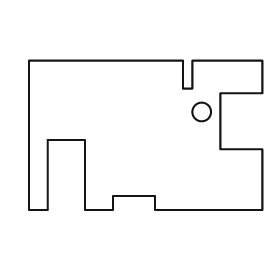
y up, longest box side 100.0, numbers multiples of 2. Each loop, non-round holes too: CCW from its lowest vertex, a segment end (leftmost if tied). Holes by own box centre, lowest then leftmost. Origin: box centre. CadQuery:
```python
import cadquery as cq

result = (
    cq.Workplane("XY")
    .moveTo(-50.0, -32.0)
    .lineTo(-42.0, -32.0)
    .lineTo(-42.0, -2.0)
    .lineTo(-26.0, -2.0)
    .lineTo(-26.0, -32.0)
    .lineTo(-14.0, -32.0)
    .lineTo(-14.0, -26.0)
    .lineTo(4.0, -26.0)
    .lineTo(4.0, -32.0)
    .lineTo(50.0, -32.0)
    .lineTo(50.0, -6.0)
    .lineTo(32.0, -6.0)
    .lineTo(32.0, 18.0)
    .lineTo(50.0, 18.0)
    .lineTo(50.0, 32.0)
    .lineTo(20.0, 32.0)
    .lineTo(20.0, 20.0)
    .lineTo(16.0, 20.0)
    .lineTo(16.0, 32.0)
    .lineTo(-50.0, 32.0)
    .close()
    .moveTo(24.0, 10.0)
    .circle(4.0)
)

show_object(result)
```